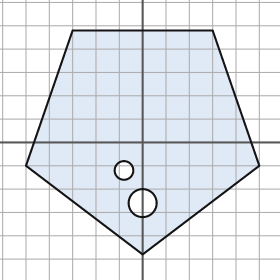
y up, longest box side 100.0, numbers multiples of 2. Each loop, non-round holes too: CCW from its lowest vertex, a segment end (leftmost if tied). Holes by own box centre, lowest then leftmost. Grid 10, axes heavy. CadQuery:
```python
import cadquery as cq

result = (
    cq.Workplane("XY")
    .moveTo(0.0, -48.0)
    .lineTo(50.0, -10.0)
    .lineTo(30.0, 48.0)
    .lineTo(-30.0, 48.0)
    .lineTo(-50.0, -10.0)
    .close()
    .moveTo(0.0, -26.0)
    .circle(6.0)
    .moveTo(-8.0, -12.0)
    .circle(4.0)
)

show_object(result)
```